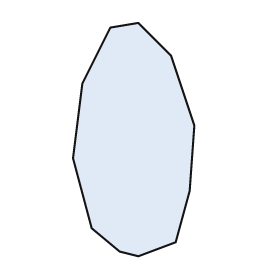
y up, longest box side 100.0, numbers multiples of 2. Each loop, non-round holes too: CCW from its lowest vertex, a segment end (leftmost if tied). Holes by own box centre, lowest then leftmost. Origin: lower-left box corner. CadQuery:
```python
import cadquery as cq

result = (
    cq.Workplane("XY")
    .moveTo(28.0, 0.0)
    .lineTo(44.0, 6.0)
    .lineTo(50.0, 28.0)
    .lineTo(52.0, 56.0)
    .lineTo(42.0, 86.0)
    .lineTo(28.0, 100.0)
    .lineTo(16.0, 98.0)
    .lineTo(4.0, 74.0)
    .lineTo(0.0, 42.0)
    .lineTo(8.0, 12.0)
    .lineTo(20.0, 2.0)
    .close()
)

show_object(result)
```